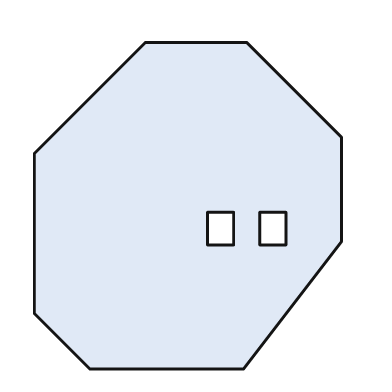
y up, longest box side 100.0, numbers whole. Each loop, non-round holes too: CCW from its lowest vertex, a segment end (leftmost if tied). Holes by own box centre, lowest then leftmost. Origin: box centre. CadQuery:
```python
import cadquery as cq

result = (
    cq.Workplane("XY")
    .moveTo(-30.0, -50.0)
    .lineTo(17.0, -50.0)
    .lineTo(47.0, -11.0)
    .lineTo(47.0, 21.0)
    .lineTo(18.0, 50.0)
    .lineTo(-13.0, 50.0)
    .lineTo(-47.0, 16.0)
    .lineTo(-47.0, -33.0)
    .close()
    .moveTo(6.0, -12.0)
    .lineTo(14.0, -12.0)
    .lineTo(14.0, -2.0)
    .lineTo(6.0, -2.0)
    .close()
    .moveTo(22.0, -12.0)
    .lineTo(30.0, -12.0)
    .lineTo(30.0, -2.0)
    .lineTo(22.0, -2.0)
    .close()
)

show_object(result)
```